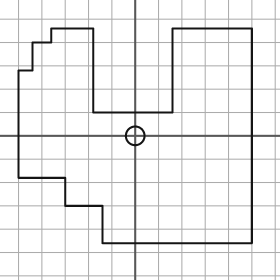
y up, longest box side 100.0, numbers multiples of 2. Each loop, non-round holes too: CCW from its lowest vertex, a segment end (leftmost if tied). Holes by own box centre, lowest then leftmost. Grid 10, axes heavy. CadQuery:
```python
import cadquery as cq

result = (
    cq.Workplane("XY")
    .moveTo(-14.0, -46.0)
    .lineTo(50.0, -46.0)
    .lineTo(50.0, 46.0)
    .lineTo(16.0, 46.0)
    .lineTo(16.0, 10.0)
    .lineTo(-18.0, 10.0)
    .lineTo(-18.0, 46.0)
    .lineTo(-36.0, 46.0)
    .lineTo(-36.0, 40.0)
    .lineTo(-44.0, 40.0)
    .lineTo(-44.0, 28.0)
    .lineTo(-50.0, 28.0)
    .lineTo(-50.0, -18.0)
    .lineTo(-30.0, -18.0)
    .lineTo(-30.0, -30.0)
    .lineTo(-14.0, -30.0)
    .close()
    .moveTo(0.0, 0.0)
    .circle(4.0)
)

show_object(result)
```